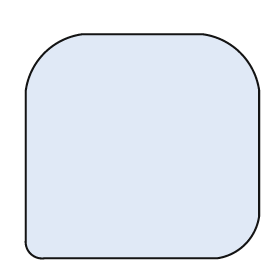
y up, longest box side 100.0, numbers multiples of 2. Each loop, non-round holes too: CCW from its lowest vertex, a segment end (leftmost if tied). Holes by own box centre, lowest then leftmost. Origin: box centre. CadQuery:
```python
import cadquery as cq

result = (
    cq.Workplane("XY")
    .moveTo(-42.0, -48.0)
    .lineTo(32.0, -48.0)
    .threePointArc((44.0, -42.0), (50.0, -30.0))
    .lineTo(50.0, 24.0)
    .threePointArc((42.0, 40.0), (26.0, 48.0))
    .lineTo(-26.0, 48.0)
    .threePointArc((-42.0, 40.0), (-50.0, 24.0))
    .lineTo(-50.0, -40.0)
    .threePointArc((-48.0, -46.0), (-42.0, -48.0))
    .close()
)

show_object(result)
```